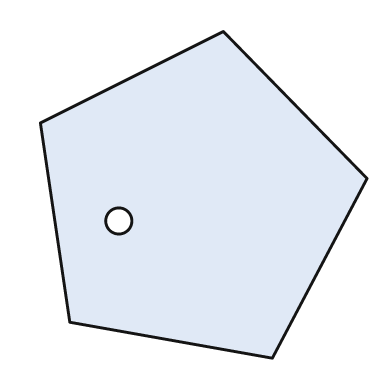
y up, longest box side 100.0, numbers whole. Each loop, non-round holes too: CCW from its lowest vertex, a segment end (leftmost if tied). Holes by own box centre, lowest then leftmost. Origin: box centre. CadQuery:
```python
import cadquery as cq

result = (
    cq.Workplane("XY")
    .moveTo(21.0, -50.0)
    .lineTo(50.0, 5.0)
    .lineTo(6.0, 50.0)
    .lineTo(-50.0, 22.0)
    .lineTo(-41.0, -39.0)
    .close()
    .moveTo(-26.0, -8.0)
    .circle(4.0)
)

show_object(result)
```